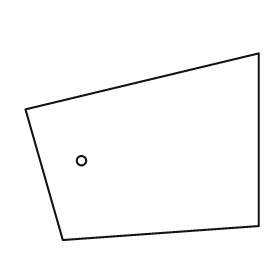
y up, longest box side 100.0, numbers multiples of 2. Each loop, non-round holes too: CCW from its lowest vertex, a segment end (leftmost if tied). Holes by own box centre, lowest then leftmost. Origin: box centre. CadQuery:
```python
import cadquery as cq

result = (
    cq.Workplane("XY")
    .moveTo(-34.0, -40.0)
    .lineTo(50.0, -34.0)
    .lineTo(50.0, 40.0)
    .lineTo(-50.0, 16.0)
    .close()
    .moveTo(-26.0, -6.0)
    .circle(2.0)
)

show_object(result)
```